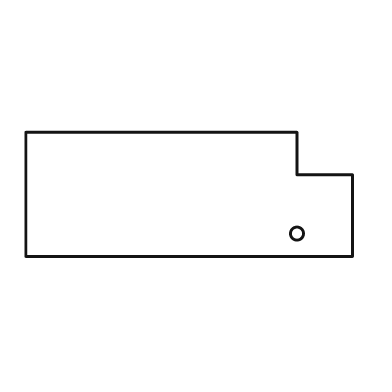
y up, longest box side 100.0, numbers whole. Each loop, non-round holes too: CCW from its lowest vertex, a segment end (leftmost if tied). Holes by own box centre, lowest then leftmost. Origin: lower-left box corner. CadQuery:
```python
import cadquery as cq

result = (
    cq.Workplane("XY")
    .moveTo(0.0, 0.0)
    .lineTo(100.0, 0.0)
    .lineTo(100.0, 25.0)
    .lineTo(83.0, 25.0)
    .lineTo(83.0, 38.0)
    .lineTo(0.0, 38.0)
    .close()
    .moveTo(83.0, 7.0)
    .circle(2.0)
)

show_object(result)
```